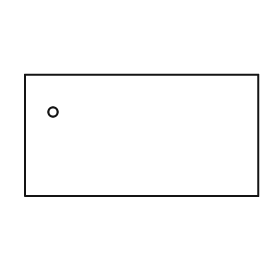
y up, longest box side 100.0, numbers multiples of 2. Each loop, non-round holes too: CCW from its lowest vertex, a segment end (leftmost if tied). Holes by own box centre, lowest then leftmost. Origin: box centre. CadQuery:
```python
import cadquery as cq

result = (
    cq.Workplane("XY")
    .moveTo(-50.0, -26.0)
    .lineTo(50.0, -26.0)
    .lineTo(50.0, 26.0)
    .lineTo(-50.0, 26.0)
    .close()
    .moveTo(-38.0, 10.0)
    .circle(2.0)
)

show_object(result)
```